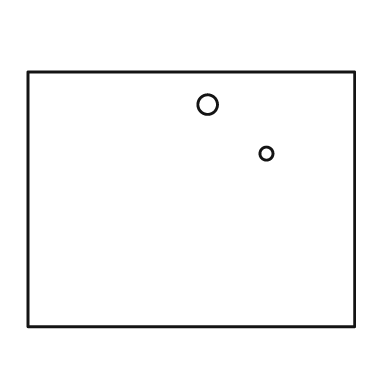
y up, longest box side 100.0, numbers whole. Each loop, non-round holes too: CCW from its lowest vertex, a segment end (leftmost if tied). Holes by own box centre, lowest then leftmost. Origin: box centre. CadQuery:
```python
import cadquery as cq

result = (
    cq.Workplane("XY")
    .moveTo(-50.0, -39.0)
    .lineTo(50.0, -39.0)
    .lineTo(50.0, 39.0)
    .lineTo(-50.0, 39.0)
    .close()
    .moveTo(23.0, 14.0)
    .circle(2.0)
    .moveTo(5.0, 29.0)
    .circle(3.0)
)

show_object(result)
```